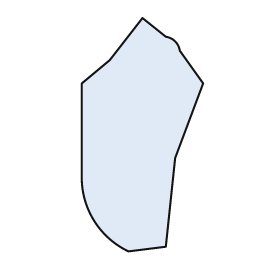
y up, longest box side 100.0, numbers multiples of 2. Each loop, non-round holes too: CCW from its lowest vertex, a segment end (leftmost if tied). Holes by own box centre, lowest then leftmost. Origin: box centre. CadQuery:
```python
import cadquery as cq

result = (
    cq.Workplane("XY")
    .moveTo(-6.0, -50.0)
    .lineTo(10.0, -48.0)
    .lineTo(14.0, -10.0)
    .lineTo(26.0, 22.0)
    .lineTo(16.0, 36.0)
    .threePointArc((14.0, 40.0), (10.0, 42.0))
    .lineTo(0.0, 50.0)
    .lineTo(-14.0, 32.0)
    .lineTo(-26.0, 22.0)
    .lineTo(-26.0, -20.0)
    .threePointArc((-20.0, -38.0), (-6.0, -50.0))
    .close()
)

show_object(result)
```